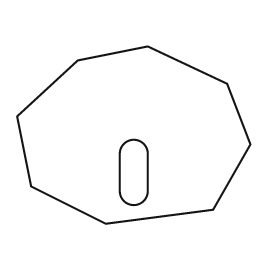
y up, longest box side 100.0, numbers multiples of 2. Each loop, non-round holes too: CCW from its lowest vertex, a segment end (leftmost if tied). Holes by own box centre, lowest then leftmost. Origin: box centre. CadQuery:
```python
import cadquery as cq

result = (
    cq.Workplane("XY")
    .moveTo(-12.0, -38.0)
    .lineTo(34.0, -32.0)
    .lineTo(50.0, -4.0)
    .lineTo(40.0, 22.0)
    .lineTo(6.0, 38.0)
    .lineTo(-24.0, 32.0)
    .lineTo(-50.0, 8.0)
    .lineTo(-44.0, -22.0)
    .close()
    .moveTo(-6.0, -24.0)
    .threePointArc((0.0, -30.0), (6.0, -24.0))
    .lineTo(6.0, -8.0)
    .threePointArc((0.0, -2.0), (-6.0, -8.0))
    .close()
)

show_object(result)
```